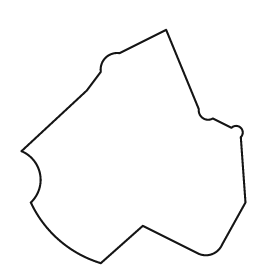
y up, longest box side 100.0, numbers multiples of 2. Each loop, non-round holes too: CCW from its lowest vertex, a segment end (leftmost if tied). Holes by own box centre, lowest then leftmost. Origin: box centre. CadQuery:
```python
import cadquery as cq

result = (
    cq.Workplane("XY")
    .moveTo(-14.0, -50.0)
    .lineTo(4.0, -34.0)
    .lineTo(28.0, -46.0)
    .threePointArc((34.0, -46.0), (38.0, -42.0))
    .lineTo(48.0, -24.0)
    .lineTo(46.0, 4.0)
    .threePointArc((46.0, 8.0), (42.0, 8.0))
    .lineTo(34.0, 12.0)
    .threePointArc((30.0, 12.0), (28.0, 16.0))
    .lineTo(14.0, 50.0)
    .lineTo(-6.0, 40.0)
    .threePointArc((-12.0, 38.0), (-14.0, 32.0))
    .lineTo(-20.0, 24.0)
    .lineTo(-48.0, -2.0)
    .threePointArc((-40.0, -12.0), (-44.0, -24.0))
    .threePointArc((-32.0, -40.0), (-14.0, -50.0))
    .close()
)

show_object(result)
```